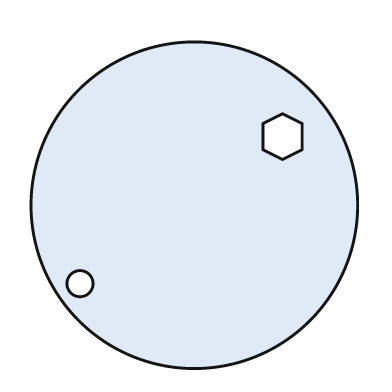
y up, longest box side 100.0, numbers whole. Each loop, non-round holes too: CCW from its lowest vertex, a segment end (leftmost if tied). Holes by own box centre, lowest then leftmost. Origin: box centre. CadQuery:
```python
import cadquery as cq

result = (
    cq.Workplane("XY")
    .moveTo(0.0, 0.0)
    .circle(50.0)
    .moveTo(-35.0, -24.0)
    .circle(4.0)
    .moveTo(27.0, 14.0)
    .lineTo(33.0, 17.0)
    .lineTo(33.0, 25.0)
    .lineTo(27.0, 28.0)
    .lineTo(21.0, 25.0)
    .lineTo(21.0, 17.0)
    .close()
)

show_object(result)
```